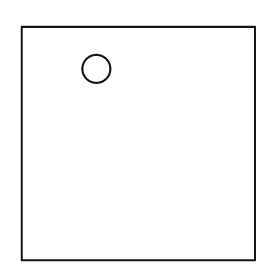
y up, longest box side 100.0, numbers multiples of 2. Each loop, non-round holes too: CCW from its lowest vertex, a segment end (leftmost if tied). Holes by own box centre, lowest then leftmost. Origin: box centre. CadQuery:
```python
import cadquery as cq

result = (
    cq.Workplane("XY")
    .moveTo(-50.0, -50.0)
    .lineTo(50.0, -50.0)
    .lineTo(50.0, 50.0)
    .lineTo(-50.0, 50.0)
    .close()
    .moveTo(-18.0, 32.0)
    .circle(6.0)
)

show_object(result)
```